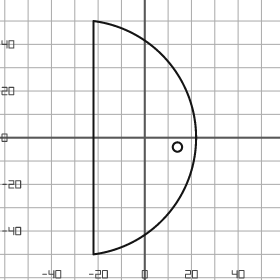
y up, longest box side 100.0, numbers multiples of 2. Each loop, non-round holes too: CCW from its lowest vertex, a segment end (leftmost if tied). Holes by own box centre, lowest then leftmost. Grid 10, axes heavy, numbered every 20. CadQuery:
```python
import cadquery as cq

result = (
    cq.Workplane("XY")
    .moveTo(-22.0, -50.0)
    .threePointArc((22.0, 0.0), (-22.0, 50.0))
    .close()
    .moveTo(14.0, -4.0)
    .circle(2.0)
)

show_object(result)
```